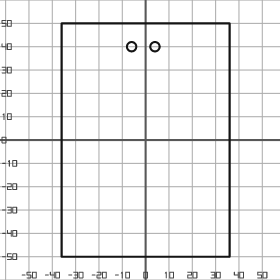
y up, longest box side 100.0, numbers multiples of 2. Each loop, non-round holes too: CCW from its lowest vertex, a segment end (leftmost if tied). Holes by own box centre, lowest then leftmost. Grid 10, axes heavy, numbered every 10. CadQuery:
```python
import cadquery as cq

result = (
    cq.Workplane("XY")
    .moveTo(-36.0, -50.0)
    .lineTo(36.0, -50.0)
    .lineTo(36.0, 50.0)
    .lineTo(-36.0, 50.0)
    .close()
    .moveTo(-6.0, 40.0)
    .circle(2.0)
    .moveTo(4.0, 40.0)
    .circle(2.0)
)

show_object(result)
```